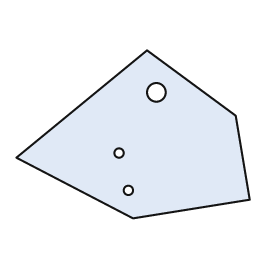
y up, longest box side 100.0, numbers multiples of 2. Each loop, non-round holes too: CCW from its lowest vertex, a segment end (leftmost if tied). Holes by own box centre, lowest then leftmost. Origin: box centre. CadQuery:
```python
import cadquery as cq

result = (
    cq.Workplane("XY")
    .moveTo(0.0, -36.0)
    .lineTo(50.0, -28.0)
    .lineTo(44.0, 8.0)
    .lineTo(6.0, 36.0)
    .lineTo(-50.0, -10.0)
    .close()
    .moveTo(-2.0, -24.0)
    .circle(2.0)
    .moveTo(-6.0, -8.0)
    .circle(2.0)
    .moveTo(10.0, 18.0)
    .circle(4.0)
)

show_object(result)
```